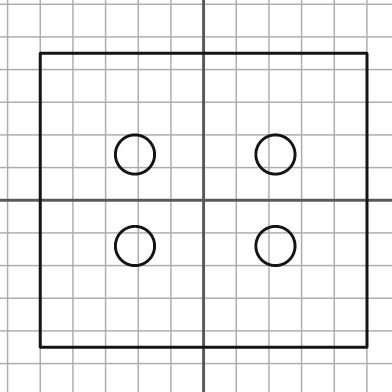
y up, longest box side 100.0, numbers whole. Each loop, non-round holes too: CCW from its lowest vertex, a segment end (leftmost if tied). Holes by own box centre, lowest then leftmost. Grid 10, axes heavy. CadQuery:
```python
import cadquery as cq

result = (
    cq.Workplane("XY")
    .moveTo(-50.0, -45.0)
    .lineTo(50.0, -45.0)
    .lineTo(50.0, 45.0)
    .lineTo(-50.0, 45.0)
    .close()
    .moveTo(-21.0, -14.0)
    .circle(6.0)
    .moveTo(22.0, -14.0)
    .circle(6.0)
    .moveTo(-21.0, 14.0)
    .circle(6.0)
    .moveTo(22.0, 14.0)
    .circle(6.0)
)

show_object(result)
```